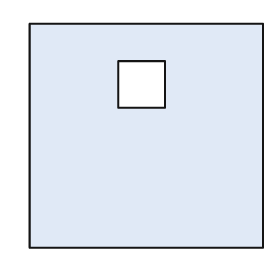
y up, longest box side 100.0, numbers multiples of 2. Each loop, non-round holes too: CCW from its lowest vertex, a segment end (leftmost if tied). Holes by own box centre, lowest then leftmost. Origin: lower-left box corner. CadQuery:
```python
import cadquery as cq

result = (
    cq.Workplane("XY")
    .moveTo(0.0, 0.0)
    .lineTo(100.0, 0.0)
    .lineTo(100.0, 96.0)
    .lineTo(0.0, 96.0)
    .close()
    .moveTo(38.0, 60.0)
    .lineTo(58.0, 60.0)
    .lineTo(58.0, 80.0)
    .lineTo(38.0, 80.0)
    .close()
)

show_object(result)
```